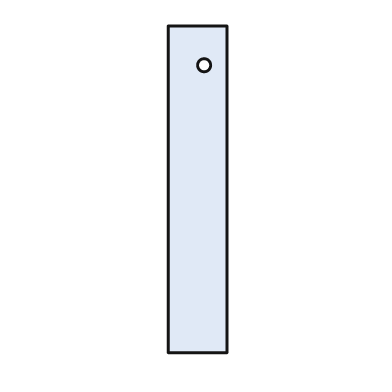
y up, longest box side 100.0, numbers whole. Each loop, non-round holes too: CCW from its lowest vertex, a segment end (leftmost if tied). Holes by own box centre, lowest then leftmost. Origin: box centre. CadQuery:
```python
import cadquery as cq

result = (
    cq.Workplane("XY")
    .moveTo(-9.0, -50.0)
    .lineTo(9.0, -50.0)
    .lineTo(9.0, 50.0)
    .lineTo(-9.0, 50.0)
    .close()
    .moveTo(2.0, 38.0)
    .circle(2.0)
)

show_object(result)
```